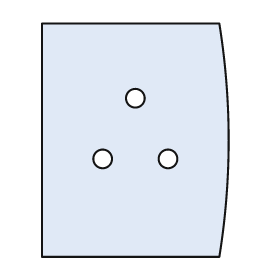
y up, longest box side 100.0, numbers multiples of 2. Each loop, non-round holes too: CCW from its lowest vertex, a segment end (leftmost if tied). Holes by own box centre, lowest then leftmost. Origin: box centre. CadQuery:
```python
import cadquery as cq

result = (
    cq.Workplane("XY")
    .moveTo(-40.0, -50.0)
    .lineTo(36.0, -50.0)
    .threePointArc((40.0, 0.0), (36.0, 50.0))
    .lineTo(-40.0, 50.0)
    .close()
    .moveTo(-14.0, -8.0)
    .circle(4.0)
    .moveTo(14.0, -8.0)
    .circle(4.0)
    .moveTo(0.0, 18.0)
    .circle(4.0)
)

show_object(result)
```